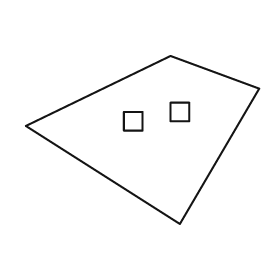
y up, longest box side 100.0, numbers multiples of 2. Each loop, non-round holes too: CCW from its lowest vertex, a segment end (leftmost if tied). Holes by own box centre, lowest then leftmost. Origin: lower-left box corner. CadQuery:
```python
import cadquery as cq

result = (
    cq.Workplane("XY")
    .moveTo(66.0, 0.0)
    .lineTo(100.0, 58.0)
    .lineTo(62.0, 72.0)
    .lineTo(0.0, 42.0)
    .close()
    .moveTo(42.0, 40.0)
    .lineTo(50.0, 40.0)
    .lineTo(50.0, 48.0)
    .lineTo(42.0, 48.0)
    .close()
    .moveTo(62.0, 44.0)
    .lineTo(70.0, 44.0)
    .lineTo(70.0, 52.0)
    .lineTo(62.0, 52.0)
    .close()
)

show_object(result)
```